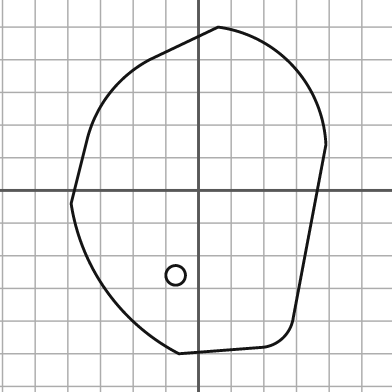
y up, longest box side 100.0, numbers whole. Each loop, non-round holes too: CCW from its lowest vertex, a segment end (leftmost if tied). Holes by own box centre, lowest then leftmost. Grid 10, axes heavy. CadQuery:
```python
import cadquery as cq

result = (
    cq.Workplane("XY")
    .moveTo(-6.0, -50.0)
    .lineTo(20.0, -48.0)
    .threePointArc((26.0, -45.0), (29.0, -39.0))
    .lineTo(39.0, 14.0)
    .threePointArc((29.0, 38.0), (6.0, 50.0))
    .lineTo(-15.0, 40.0)
    .threePointArc((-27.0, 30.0), (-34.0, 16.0))
    .lineTo(-39.0, -4.0)
    .threePointArc((-28.0, -31.0), (-6.0, -50.0))
    .close()
    .moveTo(-7.0, -26.0)
    .circle(3.0)
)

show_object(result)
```